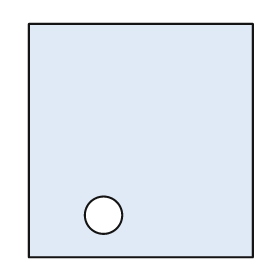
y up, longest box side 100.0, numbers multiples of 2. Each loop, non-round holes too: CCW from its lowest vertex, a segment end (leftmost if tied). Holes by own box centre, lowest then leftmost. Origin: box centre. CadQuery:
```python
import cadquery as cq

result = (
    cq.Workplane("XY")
    .moveTo(-48.0, -50.0)
    .lineTo(48.0, -50.0)
    .lineTo(48.0, 50.0)
    .lineTo(-48.0, 50.0)
    .close()
    .moveTo(-16.0, -32.0)
    .circle(8.0)
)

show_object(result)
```